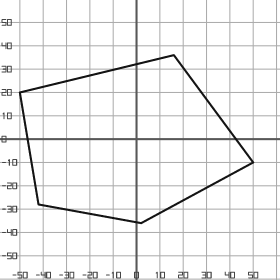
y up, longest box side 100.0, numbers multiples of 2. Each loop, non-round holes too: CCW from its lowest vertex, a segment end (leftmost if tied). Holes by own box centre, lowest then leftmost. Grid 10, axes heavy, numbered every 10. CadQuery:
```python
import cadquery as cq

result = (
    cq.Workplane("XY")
    .moveTo(2.0, -36.0)
    .lineTo(50.0, -10.0)
    .lineTo(16.0, 36.0)
    .lineTo(-50.0, 20.0)
    .lineTo(-42.0, -28.0)
    .close()
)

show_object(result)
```